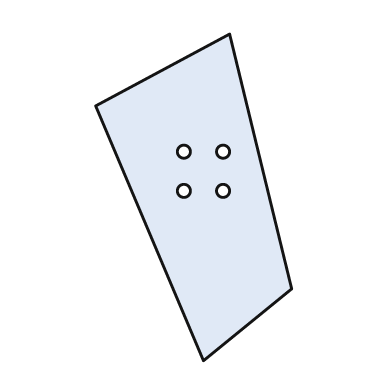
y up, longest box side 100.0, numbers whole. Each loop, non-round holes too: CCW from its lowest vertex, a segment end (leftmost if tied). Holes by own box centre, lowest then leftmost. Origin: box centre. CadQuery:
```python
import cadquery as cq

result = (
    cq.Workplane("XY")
    .moveTo(3.0, -50.0)
    .lineTo(30.0, -28.0)
    .lineTo(11.0, 50.0)
    .lineTo(-30.0, 28.0)
    .close()
    .moveTo(-3.0, 2.0)
    .circle(2.0)
    .moveTo(9.0, 2.0)
    .circle(2.0)
    .moveTo(-3.0, 14.0)
    .circle(2.0)
    .moveTo(9.0, 14.0)
    .circle(2.0)
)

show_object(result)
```